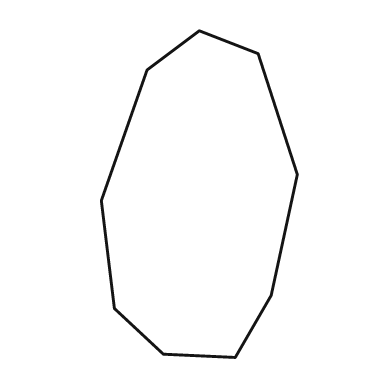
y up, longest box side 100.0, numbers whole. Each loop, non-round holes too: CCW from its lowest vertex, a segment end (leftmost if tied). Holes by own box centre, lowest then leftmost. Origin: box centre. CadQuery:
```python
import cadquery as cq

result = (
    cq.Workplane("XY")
    .moveTo(11.0, -50.0)
    .lineTo(22.0, -31.0)
    .lineTo(30.0, 6.0)
    .lineTo(18.0, 43.0)
    .lineTo(0.0, 50.0)
    .lineTo(-16.0, 38.0)
    .lineTo(-30.0, -2.0)
    .lineTo(-26.0, -35.0)
    .lineTo(-11.0, -49.0)
    .close()
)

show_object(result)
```